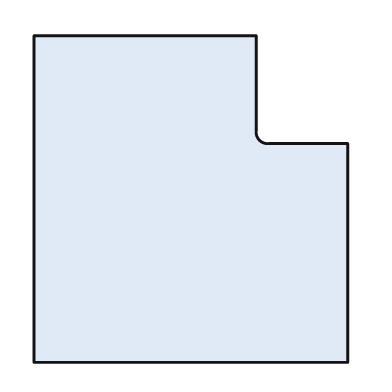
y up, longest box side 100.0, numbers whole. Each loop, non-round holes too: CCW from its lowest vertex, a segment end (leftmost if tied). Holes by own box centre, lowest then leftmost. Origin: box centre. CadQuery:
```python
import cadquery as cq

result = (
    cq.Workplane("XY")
    .moveTo(-48.0, -50.0)
    .lineTo(48.0, -50.0)
    .lineTo(48.0, 17.0)
    .lineTo(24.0, 17.0)
    .threePointArc((21.0, 18.0), (20.0, 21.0))
    .lineTo(20.0, 50.0)
    .lineTo(-48.0, 50.0)
    .close()
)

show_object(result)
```